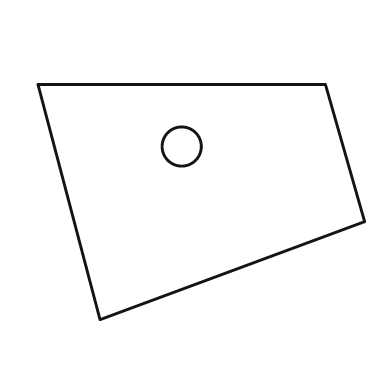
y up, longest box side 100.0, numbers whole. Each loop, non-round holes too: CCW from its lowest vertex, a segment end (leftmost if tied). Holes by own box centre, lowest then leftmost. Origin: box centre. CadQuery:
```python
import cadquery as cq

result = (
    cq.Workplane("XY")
    .moveTo(-31.0, -36.0)
    .lineTo(50.0, -6.0)
    .lineTo(38.0, 36.0)
    .lineTo(-50.0, 36.0)
    .close()
    .moveTo(-6.0, 17.0)
    .circle(6.0)
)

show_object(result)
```